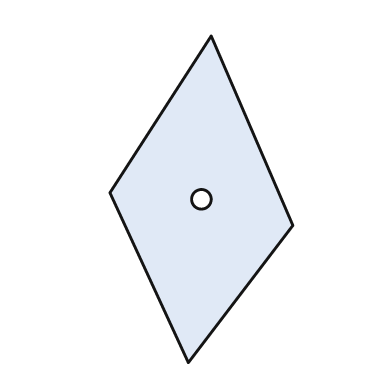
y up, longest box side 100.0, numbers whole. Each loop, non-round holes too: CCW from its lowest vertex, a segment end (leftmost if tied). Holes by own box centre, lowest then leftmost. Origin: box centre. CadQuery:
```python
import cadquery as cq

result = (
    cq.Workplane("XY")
    .moveTo(-4.0, -50.0)
    .lineTo(28.0, -8.0)
    .lineTo(3.0, 50.0)
    .lineTo(-28.0, 2.0)
    .close()
    .moveTo(0.0, 0.0)
    .circle(3.0)
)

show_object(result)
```